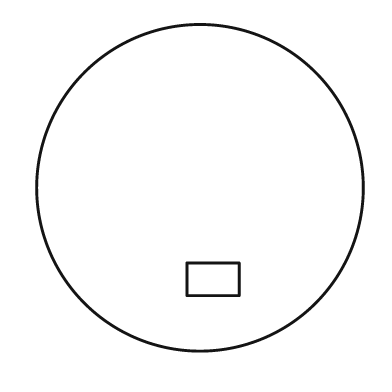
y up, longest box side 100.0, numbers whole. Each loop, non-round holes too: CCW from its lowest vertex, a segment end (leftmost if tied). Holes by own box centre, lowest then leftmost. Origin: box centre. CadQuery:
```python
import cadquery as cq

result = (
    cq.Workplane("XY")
    .moveTo(0.0, 0.0)
    .circle(50.0)
    .moveTo(-4.0, -33.0)
    .lineTo(12.0, -33.0)
    .lineTo(12.0, -23.0)
    .lineTo(-4.0, -23.0)
    .close()
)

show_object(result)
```